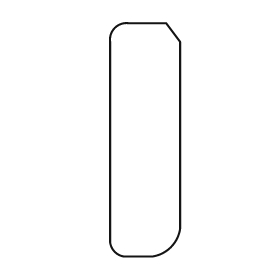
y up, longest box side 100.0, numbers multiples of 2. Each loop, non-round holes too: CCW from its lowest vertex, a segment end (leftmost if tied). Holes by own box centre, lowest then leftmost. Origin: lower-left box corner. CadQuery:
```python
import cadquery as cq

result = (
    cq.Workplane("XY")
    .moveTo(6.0, 0.0)
    .lineTo(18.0, 0.0)
    .threePointArc((26.0, 4.0), (30.0, 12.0))
    .lineTo(30.0, 92.0)
    .lineTo(24.0, 100.0)
    .lineTo(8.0, 100.0)
    .threePointArc((2.0, 98.0), (0.0, 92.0))
    .lineTo(0.0, 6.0)
    .threePointArc((2.0, 2.0), (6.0, 0.0))
    .close()
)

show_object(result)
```